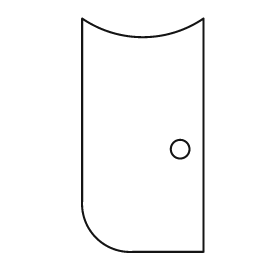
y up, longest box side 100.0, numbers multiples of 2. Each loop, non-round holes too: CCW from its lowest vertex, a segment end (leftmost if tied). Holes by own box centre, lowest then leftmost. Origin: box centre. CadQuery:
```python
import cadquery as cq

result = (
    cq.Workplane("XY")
    .moveTo(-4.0, -50.0)
    .lineTo(26.0, -50.0)
    .lineTo(26.0, 50.0)
    .threePointArc((0.0, 42.0), (-26.0, 50.0))
    .lineTo(-26.0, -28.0)
    .threePointArc((-20.0, -44.0), (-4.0, -50.0))
    .close()
    .moveTo(16.0, -6.0)
    .circle(4.0)
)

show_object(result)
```